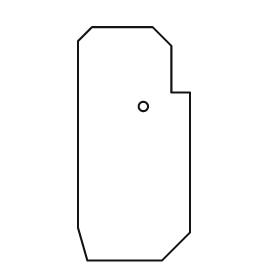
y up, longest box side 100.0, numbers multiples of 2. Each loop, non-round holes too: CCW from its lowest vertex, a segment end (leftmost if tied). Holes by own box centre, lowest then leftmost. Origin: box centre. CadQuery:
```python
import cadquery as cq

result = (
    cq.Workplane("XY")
    .moveTo(-20.0, -50.0)
    .lineTo(12.0, -50.0)
    .lineTo(24.0, -38.0)
    .lineTo(24.0, 22.0)
    .lineTo(16.0, 22.0)
    .lineTo(16.0, 42.0)
    .lineTo(8.0, 50.0)
    .lineTo(-18.0, 50.0)
    .lineTo(-24.0, 44.0)
    .lineTo(-24.0, -36.0)
    .close()
    .moveTo(4.0, 16.0)
    .circle(2.0)
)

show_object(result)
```